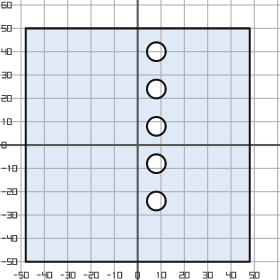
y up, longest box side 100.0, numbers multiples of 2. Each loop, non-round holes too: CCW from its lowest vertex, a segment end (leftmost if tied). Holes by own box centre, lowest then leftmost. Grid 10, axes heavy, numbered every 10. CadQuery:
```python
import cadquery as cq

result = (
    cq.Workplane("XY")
    .moveTo(-48.0, -50.0)
    .lineTo(48.0, -50.0)
    .lineTo(48.0, 50.0)
    .lineTo(-48.0, 50.0)
    .close()
    .moveTo(8.0, -24.0)
    .circle(4.0)
    .moveTo(8.0, -8.0)
    .circle(4.0)
    .moveTo(8.0, 8.0)
    .circle(4.0)
    .moveTo(8.0, 24.0)
    .circle(4.0)
    .moveTo(8.0, 40.0)
    .circle(4.0)
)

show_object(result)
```